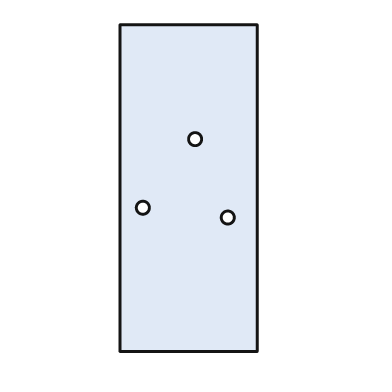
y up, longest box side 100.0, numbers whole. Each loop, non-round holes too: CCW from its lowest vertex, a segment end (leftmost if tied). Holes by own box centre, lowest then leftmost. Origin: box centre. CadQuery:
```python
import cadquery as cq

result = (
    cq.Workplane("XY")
    .moveTo(-21.0, -50.0)
    .lineTo(21.0, -50.0)
    .lineTo(21.0, 50.0)
    .lineTo(-21.0, 50.0)
    .close()
    .moveTo(12.0, -9.0)
    .circle(2.0)
    .moveTo(-14.0, -6.0)
    .circle(2.0)
    .moveTo(2.0, 15.0)
    .circle(2.0)
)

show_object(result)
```